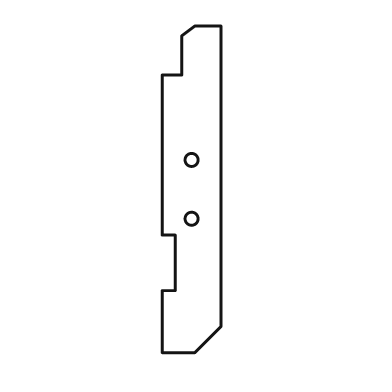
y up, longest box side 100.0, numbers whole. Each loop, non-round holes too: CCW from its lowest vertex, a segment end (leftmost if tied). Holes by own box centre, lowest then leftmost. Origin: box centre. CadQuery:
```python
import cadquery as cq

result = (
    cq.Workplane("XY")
    .moveTo(-9.0, -50.0)
    .lineTo(1.0, -50.0)
    .lineTo(9.0, -42.0)
    .lineTo(9.0, 50.0)
    .lineTo(1.0, 50.0)
    .lineTo(-3.0, 47.0)
    .lineTo(-3.0, 35.0)
    .lineTo(-9.0, 35.0)
    .lineTo(-9.0, -14.0)
    .lineTo(-5.0, -14.0)
    .lineTo(-5.0, -31.0)
    .lineTo(-9.0, -31.0)
    .close()
    .moveTo(0.0, -9.0)
    .circle(2.0)
    .moveTo(0.0, 9.0)
    .circle(2.0)
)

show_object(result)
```